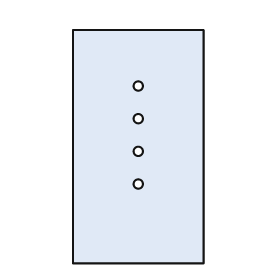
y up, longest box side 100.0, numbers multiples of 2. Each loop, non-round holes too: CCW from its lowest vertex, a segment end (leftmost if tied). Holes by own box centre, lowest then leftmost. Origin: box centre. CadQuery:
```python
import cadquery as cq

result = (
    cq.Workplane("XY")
    .moveTo(-28.0, -50.0)
    .lineTo(28.0, -50.0)
    .lineTo(28.0, 50.0)
    .lineTo(-28.0, 50.0)
    .close()
    .moveTo(0.0, -16.0)
    .circle(2.0)
    .moveTo(0.0, -2.0)
    .circle(2.0)
    .moveTo(0.0, 12.0)
    .circle(2.0)
    .moveTo(0.0, 26.0)
    .circle(2.0)
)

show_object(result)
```